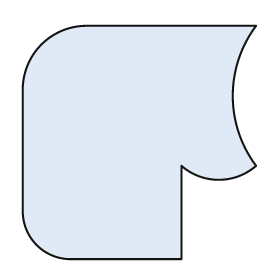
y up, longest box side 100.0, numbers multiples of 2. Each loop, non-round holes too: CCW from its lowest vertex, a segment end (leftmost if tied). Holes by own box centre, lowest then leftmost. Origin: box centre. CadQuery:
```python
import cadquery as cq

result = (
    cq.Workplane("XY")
    .moveTo(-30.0, -50.0)
    .lineTo(18.0, -50.0)
    .lineTo(18.0, -10.0)
    .threePointArc((34.0, -16.0), (50.0, -10.0))
    .threePointArc((40.0, 20.0), (50.0, 50.0))
    .lineTo(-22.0, 50.0)
    .threePointArc((-42.0, 42.0), (-50.0, 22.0))
    .lineTo(-50.0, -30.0)
    .threePointArc((-44.0, -44.0), (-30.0, -50.0))
    .close()
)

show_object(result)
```